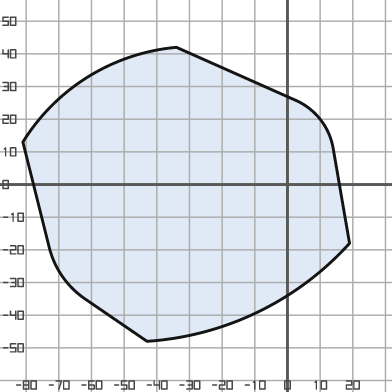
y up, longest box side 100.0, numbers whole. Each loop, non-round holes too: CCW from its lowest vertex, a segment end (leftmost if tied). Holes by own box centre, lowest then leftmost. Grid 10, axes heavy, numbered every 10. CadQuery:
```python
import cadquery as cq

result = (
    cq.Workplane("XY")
    .moveTo(-43.0, -48.0)
    .threePointArc((-9.0, -39.0), (19.0, -18.0))
    .lineTo(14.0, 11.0)
    .threePointArc((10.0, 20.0), (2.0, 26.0))
    .lineTo(-34.0, 42.0)
    .threePointArc((-61.0, 33.0), (-81.0, 13.0))
    .lineTo(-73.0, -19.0)
    .threePointArc((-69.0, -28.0), (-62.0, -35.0))
    .close()
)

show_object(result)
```